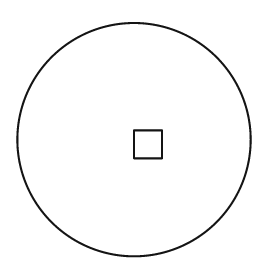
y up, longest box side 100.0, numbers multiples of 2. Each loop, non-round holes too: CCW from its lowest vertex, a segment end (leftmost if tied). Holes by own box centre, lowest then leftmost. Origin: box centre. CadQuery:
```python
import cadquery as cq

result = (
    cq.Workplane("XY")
    .moveTo(0.0, 0.0)
    .circle(50.0)
    .moveTo(0.0, -8.0)
    .lineTo(12.0, -8.0)
    .lineTo(12.0, 4.0)
    .lineTo(0.0, 4.0)
    .close()
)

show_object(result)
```